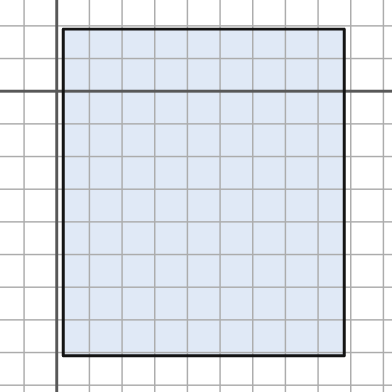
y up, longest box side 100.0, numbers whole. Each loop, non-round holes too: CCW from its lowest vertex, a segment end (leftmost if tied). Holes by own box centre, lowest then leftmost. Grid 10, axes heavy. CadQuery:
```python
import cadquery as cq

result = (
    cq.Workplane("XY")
    .moveTo(2.0, -81.0)
    .lineTo(88.0, -81.0)
    .lineTo(88.0, 19.0)
    .lineTo(2.0, 19.0)
    .close()
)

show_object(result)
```